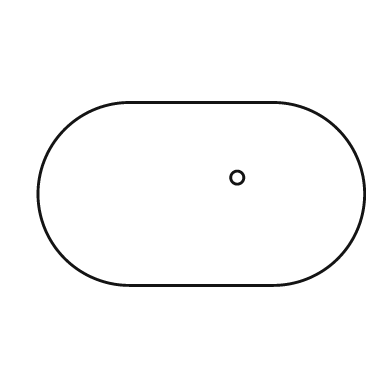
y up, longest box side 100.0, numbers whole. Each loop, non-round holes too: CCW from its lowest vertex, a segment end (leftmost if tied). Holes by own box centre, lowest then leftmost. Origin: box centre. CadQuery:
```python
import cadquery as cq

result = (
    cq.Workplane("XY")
    .moveTo(-22.0, -28.0)
    .lineTo(22.0, -28.0)
    .threePointArc((50.0, 0.0), (22.0, 28.0))
    .lineTo(-22.0, 28.0)
    .threePointArc((-50.0, 0.0), (-22.0, -28.0))
    .close()
    .moveTo(11.0, 5.0)
    .circle(2.0)
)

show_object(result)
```